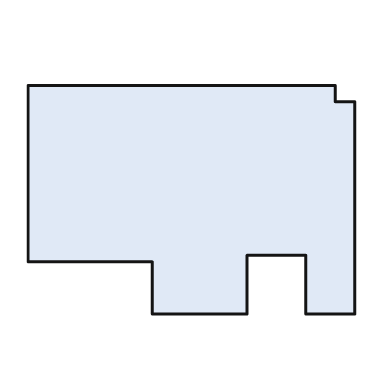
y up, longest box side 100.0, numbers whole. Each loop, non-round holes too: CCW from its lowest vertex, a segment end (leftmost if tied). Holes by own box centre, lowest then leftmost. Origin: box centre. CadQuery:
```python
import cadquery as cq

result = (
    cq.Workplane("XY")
    .moveTo(-12.0, -35.0)
    .lineTo(17.0, -35.0)
    .lineTo(17.0, -17.0)
    .lineTo(35.0, -17.0)
    .lineTo(35.0, -35.0)
    .lineTo(50.0, -35.0)
    .lineTo(50.0, 30.0)
    .lineTo(44.0, 30.0)
    .lineTo(44.0, 35.0)
    .lineTo(-50.0, 35.0)
    .lineTo(-50.0, -19.0)
    .lineTo(-12.0, -19.0)
    .close()
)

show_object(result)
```